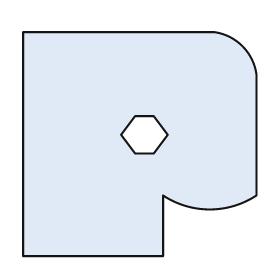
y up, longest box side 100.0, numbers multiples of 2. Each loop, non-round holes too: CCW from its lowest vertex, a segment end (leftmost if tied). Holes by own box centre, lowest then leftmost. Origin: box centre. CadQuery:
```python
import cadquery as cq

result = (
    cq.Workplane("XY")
    .moveTo(-50.0, -48.0)
    .lineTo(10.0, -48.0)
    .lineTo(10.0, -22.0)
    .threePointArc((30.0, -28.0), (50.0, -22.0))
    .lineTo(50.0, 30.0)
    .threePointArc((44.0, 42.0), (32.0, 48.0))
    .lineTo(-50.0, 48.0)
    .close()
    .moveTo(-2.0, -4.0)
    .lineTo(6.0, -4.0)
    .lineTo(12.0, 4.0)
    .lineTo(6.0, 12.0)
    .lineTo(-2.0, 12.0)
    .lineTo(-8.0, 4.0)
    .close()
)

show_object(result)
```